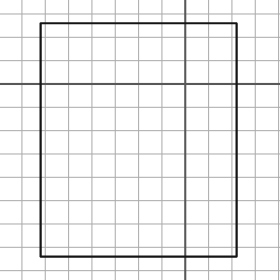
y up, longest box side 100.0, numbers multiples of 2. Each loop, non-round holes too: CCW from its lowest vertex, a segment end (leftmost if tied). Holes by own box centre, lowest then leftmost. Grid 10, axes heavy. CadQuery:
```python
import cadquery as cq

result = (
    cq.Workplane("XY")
    .moveTo(-62.0, -74.0)
    .lineTo(22.0, -74.0)
    .lineTo(22.0, 26.0)
    .lineTo(-62.0, 26.0)
    .close()
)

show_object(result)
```